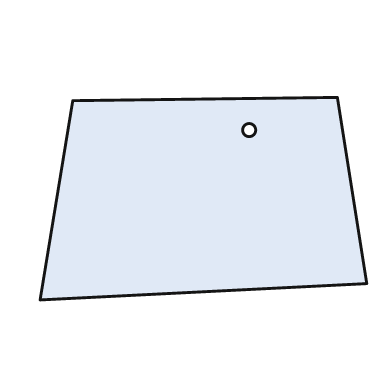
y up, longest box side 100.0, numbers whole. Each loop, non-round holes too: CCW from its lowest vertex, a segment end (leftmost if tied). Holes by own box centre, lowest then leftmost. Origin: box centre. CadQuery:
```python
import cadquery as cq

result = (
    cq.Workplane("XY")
    .moveTo(-50.0, -31.0)
    .lineTo(50.0, -26.0)
    .lineTo(41.0, 31.0)
    .lineTo(-40.0, 30.0)
    .close()
    .moveTo(14.0, 21.0)
    .circle(2.0)
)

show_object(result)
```